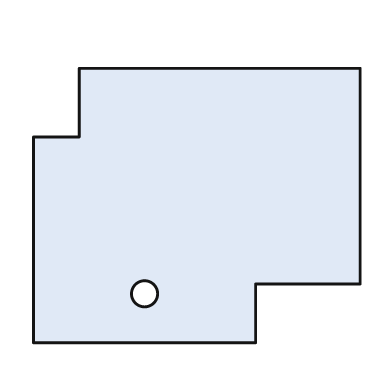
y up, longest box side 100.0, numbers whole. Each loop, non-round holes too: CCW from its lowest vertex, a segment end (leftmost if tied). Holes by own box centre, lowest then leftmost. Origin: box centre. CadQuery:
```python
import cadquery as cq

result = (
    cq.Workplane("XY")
    .moveTo(-50.0, -42.0)
    .lineTo(18.0, -42.0)
    .lineTo(18.0, -24.0)
    .lineTo(50.0, -24.0)
    .lineTo(50.0, 42.0)
    .lineTo(-36.0, 42.0)
    .lineTo(-36.0, 21.0)
    .lineTo(-50.0, 21.0)
    .close()
    .moveTo(-16.0, -27.0)
    .circle(4.0)
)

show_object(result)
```